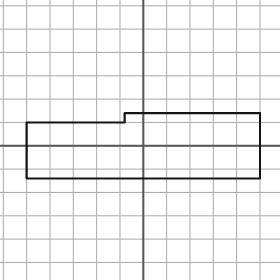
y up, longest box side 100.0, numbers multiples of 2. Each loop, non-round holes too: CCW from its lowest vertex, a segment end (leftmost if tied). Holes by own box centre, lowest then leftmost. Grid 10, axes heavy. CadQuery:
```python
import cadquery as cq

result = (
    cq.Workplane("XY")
    .moveTo(-50.0, -14.0)
    .lineTo(50.0, -14.0)
    .lineTo(50.0, 14.0)
    .lineTo(-8.0, 14.0)
    .lineTo(-8.0, 10.0)
    .lineTo(-50.0, 10.0)
    .close()
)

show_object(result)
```